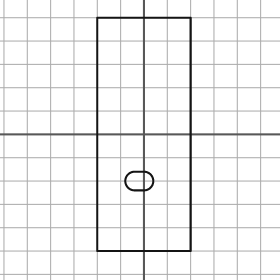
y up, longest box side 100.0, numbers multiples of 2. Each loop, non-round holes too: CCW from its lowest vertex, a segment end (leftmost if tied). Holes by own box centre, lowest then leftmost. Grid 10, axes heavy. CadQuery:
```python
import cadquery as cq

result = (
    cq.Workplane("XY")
    .moveTo(-20.0, -50.0)
    .lineTo(20.0, -50.0)
    .lineTo(20.0, 50.0)
    .lineTo(-20.0, 50.0)
    .close()
    .moveTo(-4.0, -24.0)
    .lineTo(0.0, -24.0)
    .threePointArc((4.0, -20.0), (0.0, -16.0))
    .lineTo(-4.0, -16.0)
    .threePointArc((-8.0, -20.0), (-4.0, -24.0))
    .close()
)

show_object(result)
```